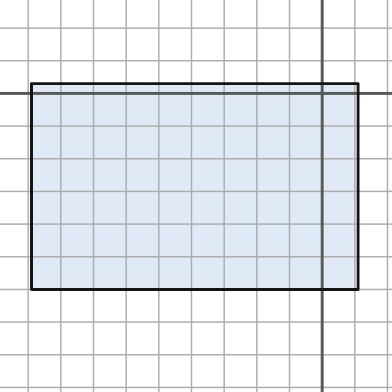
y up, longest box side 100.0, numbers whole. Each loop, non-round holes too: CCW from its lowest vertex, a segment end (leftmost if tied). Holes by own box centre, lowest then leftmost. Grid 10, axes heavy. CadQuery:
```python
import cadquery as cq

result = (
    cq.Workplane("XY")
    .moveTo(-89.0, -60.0)
    .lineTo(11.0, -60.0)
    .lineTo(11.0, 3.0)
    .lineTo(-89.0, 3.0)
    .close()
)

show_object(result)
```